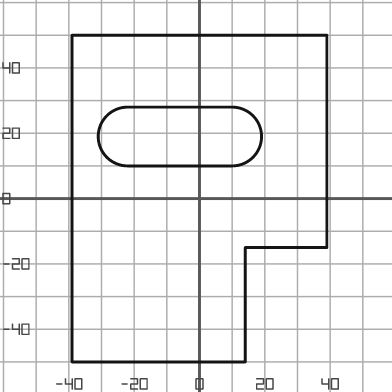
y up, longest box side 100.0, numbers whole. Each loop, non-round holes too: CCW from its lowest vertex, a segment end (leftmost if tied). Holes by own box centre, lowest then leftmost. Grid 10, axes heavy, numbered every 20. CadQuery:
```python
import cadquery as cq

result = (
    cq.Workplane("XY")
    .moveTo(-39.0, -50.0)
    .lineTo(14.0, -50.0)
    .lineTo(14.0, -15.0)
    .lineTo(39.0, -15.0)
    .lineTo(39.0, 50.0)
    .lineTo(-39.0, 50.0)
    .close()
    .moveTo(-22.0, 10.0)
    .lineTo(10.0, 10.0)
    .threePointArc((19.0, 19.0), (10.0, 28.0))
    .lineTo(-22.0, 28.0)
    .threePointArc((-31.0, 19.0), (-22.0, 10.0))
    .close()
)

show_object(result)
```